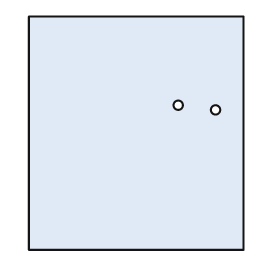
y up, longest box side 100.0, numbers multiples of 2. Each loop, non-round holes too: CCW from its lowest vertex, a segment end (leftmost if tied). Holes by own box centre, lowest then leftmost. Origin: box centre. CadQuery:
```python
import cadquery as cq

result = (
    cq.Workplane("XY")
    .moveTo(-46.0, -50.0)
    .lineTo(46.0, -50.0)
    .lineTo(46.0, 50.0)
    .lineTo(-46.0, 50.0)
    .close()
    .moveTo(34.0, 10.0)
    .circle(2.0)
    .moveTo(18.0, 12.0)
    .circle(2.0)
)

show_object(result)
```